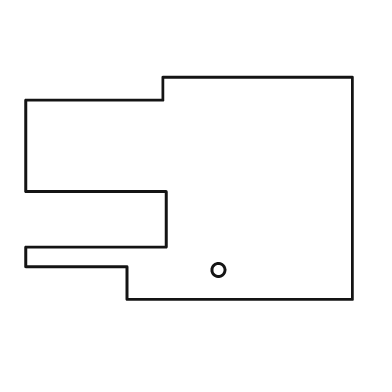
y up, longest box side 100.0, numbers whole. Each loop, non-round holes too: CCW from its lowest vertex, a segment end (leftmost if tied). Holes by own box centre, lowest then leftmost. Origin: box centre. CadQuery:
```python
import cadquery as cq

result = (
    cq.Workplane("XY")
    .moveTo(-19.0, -34.0)
    .lineTo(50.0, -34.0)
    .lineTo(50.0, 34.0)
    .lineTo(-8.0, 34.0)
    .lineTo(-8.0, 27.0)
    .lineTo(-50.0, 27.0)
    .lineTo(-50.0, -1.0)
    .lineTo(-7.0, -1.0)
    .lineTo(-7.0, -18.0)
    .lineTo(-50.0, -18.0)
    .lineTo(-50.0, -24.0)
    .lineTo(-19.0, -24.0)
    .close()
    .moveTo(9.0, -25.0)
    .circle(2.0)
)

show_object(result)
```